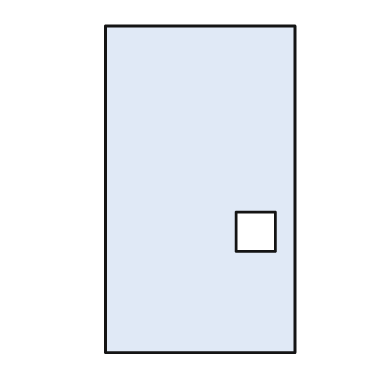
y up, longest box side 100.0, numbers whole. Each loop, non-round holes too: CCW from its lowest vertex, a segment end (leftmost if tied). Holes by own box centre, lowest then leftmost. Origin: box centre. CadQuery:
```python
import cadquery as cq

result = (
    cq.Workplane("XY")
    .moveTo(-29.0, -50.0)
    .lineTo(29.0, -50.0)
    .lineTo(29.0, 50.0)
    .lineTo(-29.0, 50.0)
    .close()
    .moveTo(11.0, -19.0)
    .lineTo(23.0, -19.0)
    .lineTo(23.0, -7.0)
    .lineTo(11.0, -7.0)
    .close()
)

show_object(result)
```